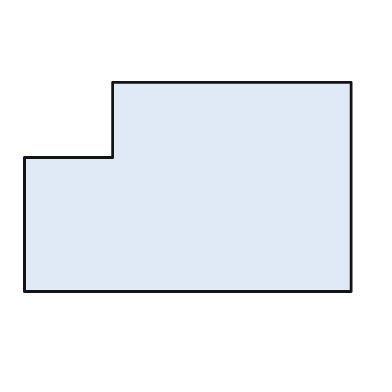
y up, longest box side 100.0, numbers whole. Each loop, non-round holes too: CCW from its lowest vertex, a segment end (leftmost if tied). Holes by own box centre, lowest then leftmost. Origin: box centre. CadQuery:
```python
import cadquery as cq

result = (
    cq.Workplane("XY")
    .moveTo(-50.0, -32.0)
    .lineTo(50.0, -32.0)
    .lineTo(50.0, 32.0)
    .lineTo(-23.0, 32.0)
    .lineTo(-23.0, 9.0)
    .lineTo(-50.0, 9.0)
    .close()
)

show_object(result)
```